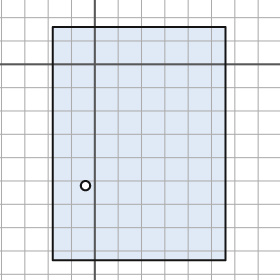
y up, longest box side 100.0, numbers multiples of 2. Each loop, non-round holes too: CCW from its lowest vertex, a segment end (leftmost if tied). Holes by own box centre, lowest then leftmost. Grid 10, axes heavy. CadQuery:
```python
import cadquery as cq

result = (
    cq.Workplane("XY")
    .moveTo(-18.0, -84.0)
    .lineTo(56.0, -84.0)
    .lineTo(56.0, 16.0)
    .lineTo(-18.0, 16.0)
    .close()
    .moveTo(-4.0, -52.0)
    .circle(2.0)
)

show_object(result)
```